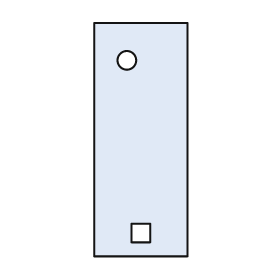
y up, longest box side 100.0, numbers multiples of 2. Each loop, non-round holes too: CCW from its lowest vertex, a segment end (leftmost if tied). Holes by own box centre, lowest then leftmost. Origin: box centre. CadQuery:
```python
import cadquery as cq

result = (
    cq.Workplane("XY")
    .moveTo(-20.0, -50.0)
    .lineTo(20.0, -50.0)
    .lineTo(20.0, 50.0)
    .lineTo(-20.0, 50.0)
    .close()
    .moveTo(-4.0, -44.0)
    .lineTo(4.0, -44.0)
    .lineTo(4.0, -36.0)
    .lineTo(-4.0, -36.0)
    .close()
    .moveTo(-6.0, 34.0)
    .circle(4.0)
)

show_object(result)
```